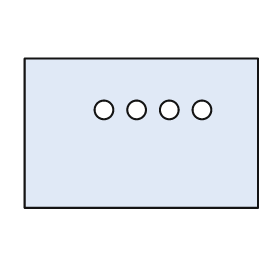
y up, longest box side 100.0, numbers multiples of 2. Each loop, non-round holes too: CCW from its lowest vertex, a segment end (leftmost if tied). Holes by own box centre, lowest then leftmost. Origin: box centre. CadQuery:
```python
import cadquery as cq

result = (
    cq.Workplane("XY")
    .moveTo(-50.0, -32.0)
    .lineTo(50.0, -32.0)
    .lineTo(50.0, 32.0)
    .lineTo(-50.0, 32.0)
    .close()
    .moveTo(-16.0, 10.0)
    .circle(4.0)
    .moveTo(-2.0, 10.0)
    .circle(4.0)
    .moveTo(12.0, 10.0)
    .circle(4.0)
    .moveTo(26.0, 10.0)
    .circle(4.0)
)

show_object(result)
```